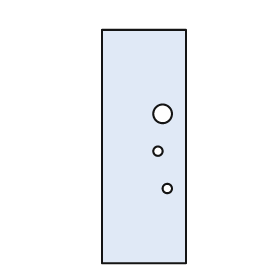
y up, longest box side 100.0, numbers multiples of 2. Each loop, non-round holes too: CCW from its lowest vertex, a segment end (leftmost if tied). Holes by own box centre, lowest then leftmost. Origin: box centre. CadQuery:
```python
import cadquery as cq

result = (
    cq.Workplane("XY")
    .moveTo(-18.0, -50.0)
    .lineTo(18.0, -50.0)
    .lineTo(18.0, 50.0)
    .lineTo(-18.0, 50.0)
    .close()
    .moveTo(10.0, -18.0)
    .circle(2.0)
    .moveTo(6.0, -2.0)
    .circle(2.0)
    .moveTo(8.0, 14.0)
    .circle(4.0)
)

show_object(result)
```